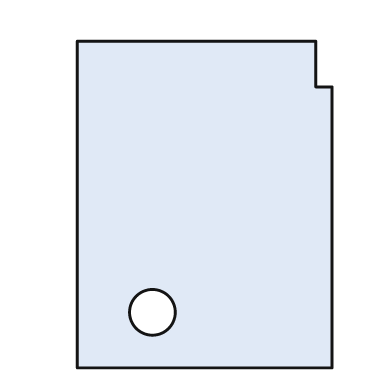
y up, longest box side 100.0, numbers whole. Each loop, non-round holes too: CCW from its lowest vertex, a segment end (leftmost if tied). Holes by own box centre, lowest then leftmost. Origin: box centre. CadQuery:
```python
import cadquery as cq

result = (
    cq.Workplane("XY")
    .moveTo(-39.0, -50.0)
    .lineTo(39.0, -50.0)
    .lineTo(39.0, 36.0)
    .lineTo(34.0, 36.0)
    .lineTo(34.0, 50.0)
    .lineTo(-39.0, 50.0)
    .close()
    .moveTo(-16.0, -33.0)
    .circle(7.0)
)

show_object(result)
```